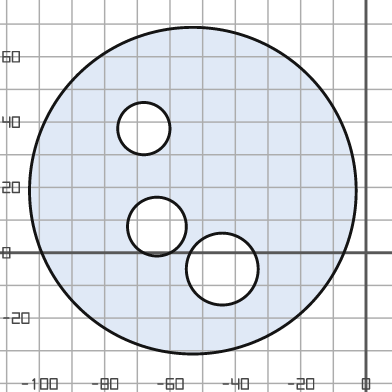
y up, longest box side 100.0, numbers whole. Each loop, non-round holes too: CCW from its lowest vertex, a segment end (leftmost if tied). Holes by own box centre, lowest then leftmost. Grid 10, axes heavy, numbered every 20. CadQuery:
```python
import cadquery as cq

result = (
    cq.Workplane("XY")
    .moveTo(-53.0, 19.0)
    .circle(50.0)
    .moveTo(-44.0, -5.0)
    .circle(11.0)
    .moveTo(-64.0, 8.0)
    .circle(9.0)
    .moveTo(-68.0, 38.0)
    .circle(8.0)
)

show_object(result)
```